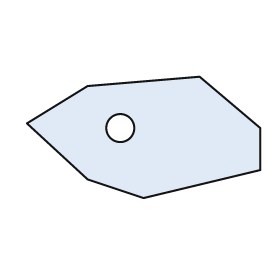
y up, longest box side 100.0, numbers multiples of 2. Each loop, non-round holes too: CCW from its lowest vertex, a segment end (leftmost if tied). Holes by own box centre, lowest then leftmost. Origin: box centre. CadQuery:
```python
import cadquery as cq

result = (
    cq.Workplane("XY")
    .moveTo(0.0, -26.0)
    .lineTo(50.0, -14.0)
    .lineTo(50.0, 4.0)
    .lineTo(24.0, 26.0)
    .lineTo(-24.0, 22.0)
    .lineTo(-50.0, 6.0)
    .lineTo(-24.0, -18.0)
    .close()
    .moveTo(-10.0, 4.0)
    .circle(6.0)
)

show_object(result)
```